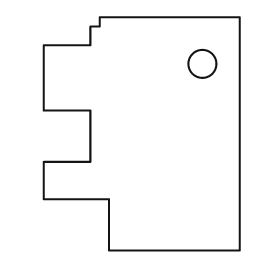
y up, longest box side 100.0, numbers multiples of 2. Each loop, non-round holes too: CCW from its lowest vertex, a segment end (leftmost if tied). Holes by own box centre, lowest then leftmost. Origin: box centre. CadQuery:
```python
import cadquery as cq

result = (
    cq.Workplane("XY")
    .moveTo(-14.0, -50.0)
    .lineTo(42.0, -50.0)
    .lineTo(42.0, 50.0)
    .lineTo(-18.0, 50.0)
    .lineTo(-18.0, 46.0)
    .lineTo(-22.0, 46.0)
    .lineTo(-22.0, 38.0)
    .lineTo(-42.0, 38.0)
    .lineTo(-42.0, 10.0)
    .lineTo(-22.0, 10.0)
    .lineTo(-22.0, -12.0)
    .lineTo(-42.0, -12.0)
    .lineTo(-42.0, -28.0)
    .lineTo(-14.0, -28.0)
    .close()
    .moveTo(26.0, 30.0)
    .circle(6.0)
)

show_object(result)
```